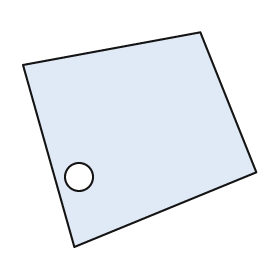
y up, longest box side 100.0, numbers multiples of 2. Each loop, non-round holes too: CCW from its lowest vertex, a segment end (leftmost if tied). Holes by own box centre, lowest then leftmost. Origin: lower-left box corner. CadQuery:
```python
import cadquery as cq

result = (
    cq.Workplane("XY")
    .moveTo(22.0, 0.0)
    .lineTo(100.0, 32.0)
    .lineTo(76.0, 92.0)
    .lineTo(0.0, 78.0)
    .close()
    .moveTo(24.0, 30.0)
    .circle(6.0)
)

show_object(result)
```